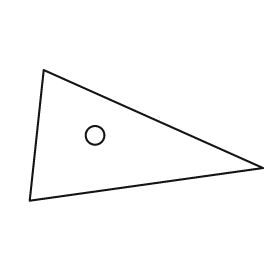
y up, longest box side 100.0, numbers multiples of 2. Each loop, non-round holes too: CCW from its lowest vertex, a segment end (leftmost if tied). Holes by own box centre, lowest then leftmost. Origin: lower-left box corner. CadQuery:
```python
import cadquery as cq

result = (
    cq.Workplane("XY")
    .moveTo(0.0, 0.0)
    .lineTo(100.0, 14.0)
    .lineTo(6.0, 56.0)
    .close()
    .moveTo(28.0, 28.0)
    .circle(4.0)
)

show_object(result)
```